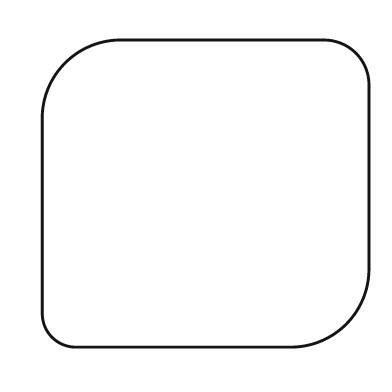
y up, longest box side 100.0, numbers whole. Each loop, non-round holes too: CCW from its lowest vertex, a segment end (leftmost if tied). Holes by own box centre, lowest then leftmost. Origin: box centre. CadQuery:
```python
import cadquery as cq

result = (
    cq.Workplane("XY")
    .moveTo(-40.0, -47.0)
    .lineTo(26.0, -47.0)
    .threePointArc((43.0, -40.0), (50.0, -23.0))
    .lineTo(50.0, 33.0)
    .threePointArc((46.0, 43.0), (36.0, 47.0))
    .lineTo(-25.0, 47.0)
    .threePointArc((-43.0, 40.0), (-50.0, 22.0))
    .lineTo(-50.0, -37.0)
    .threePointArc((-47.0, -44.0), (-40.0, -47.0))
    .close()
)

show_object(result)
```